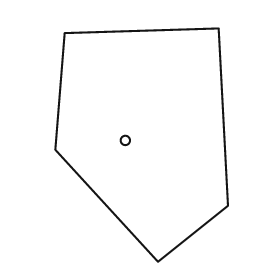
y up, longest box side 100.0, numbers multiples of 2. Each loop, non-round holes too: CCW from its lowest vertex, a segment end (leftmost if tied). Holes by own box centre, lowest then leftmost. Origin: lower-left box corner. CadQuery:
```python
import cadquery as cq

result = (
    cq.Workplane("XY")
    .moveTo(44.0, 0.0)
    .lineTo(74.0, 24.0)
    .lineTo(70.0, 100.0)
    .lineTo(4.0, 98.0)
    .lineTo(0.0, 48.0)
    .close()
    .moveTo(30.0, 52.0)
    .circle(2.0)
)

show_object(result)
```